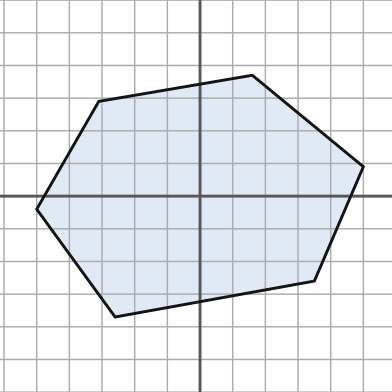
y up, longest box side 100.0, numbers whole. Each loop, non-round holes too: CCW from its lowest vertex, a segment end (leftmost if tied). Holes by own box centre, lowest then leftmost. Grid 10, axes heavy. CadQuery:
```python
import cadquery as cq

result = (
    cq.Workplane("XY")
    .moveTo(-26.0, -37.0)
    .lineTo(35.0, -26.0)
    .lineTo(50.0, 9.0)
    .lineTo(16.0, 37.0)
    .lineTo(-31.0, 29.0)
    .lineTo(-50.0, -4.0)
    .close()
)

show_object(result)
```